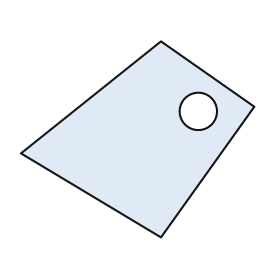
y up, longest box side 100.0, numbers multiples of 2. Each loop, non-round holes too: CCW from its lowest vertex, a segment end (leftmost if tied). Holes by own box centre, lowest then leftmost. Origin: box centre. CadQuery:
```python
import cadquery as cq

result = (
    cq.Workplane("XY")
    .moveTo(10.0, -42.0)
    .lineTo(50.0, 14.0)
    .lineTo(10.0, 42.0)
    .lineTo(-50.0, -6.0)
    .close()
    .moveTo(26.0, 12.0)
    .circle(8.0)
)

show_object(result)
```